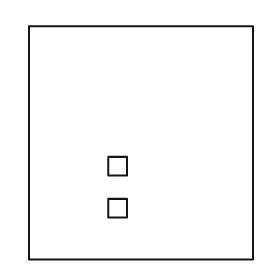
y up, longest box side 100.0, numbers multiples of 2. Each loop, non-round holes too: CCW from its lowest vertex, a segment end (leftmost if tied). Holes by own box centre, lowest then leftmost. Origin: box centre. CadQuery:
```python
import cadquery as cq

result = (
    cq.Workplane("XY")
    .moveTo(-48.0, -50.0)
    .lineTo(48.0, -50.0)
    .lineTo(48.0, 50.0)
    .lineTo(-48.0, 50.0)
    .close()
    .moveTo(-14.0, -32.0)
    .lineTo(-6.0, -32.0)
    .lineTo(-6.0, -24.0)
    .lineTo(-14.0, -24.0)
    .close()
    .moveTo(-14.0, -14.0)
    .lineTo(-6.0, -14.0)
    .lineTo(-6.0, -6.0)
    .lineTo(-14.0, -6.0)
    .close()
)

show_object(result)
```